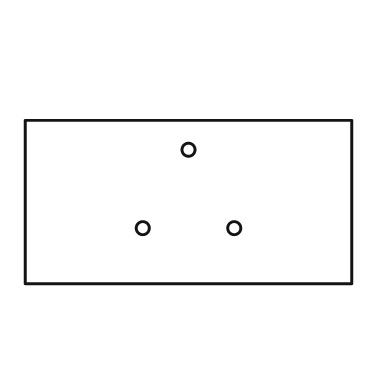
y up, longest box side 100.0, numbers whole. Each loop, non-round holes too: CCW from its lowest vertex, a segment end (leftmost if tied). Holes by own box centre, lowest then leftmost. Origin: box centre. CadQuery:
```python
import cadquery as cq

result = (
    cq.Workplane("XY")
    .moveTo(-50.0, -25.0)
    .lineTo(50.0, -25.0)
    .lineTo(50.0, 25.0)
    .lineTo(-50.0, 25.0)
    .close()
    .moveTo(-14.0, -8.0)
    .circle(2.0)
    .moveTo(14.0, -8.0)
    .circle(2.0)
    .moveTo(0.0, 16.0)
    .circle(2.0)
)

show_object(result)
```